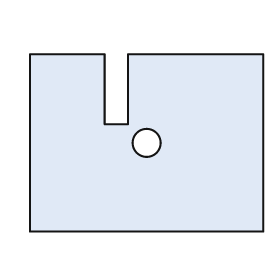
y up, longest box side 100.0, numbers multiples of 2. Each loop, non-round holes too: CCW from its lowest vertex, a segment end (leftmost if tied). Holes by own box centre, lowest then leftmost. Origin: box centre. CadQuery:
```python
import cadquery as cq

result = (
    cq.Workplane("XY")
    .moveTo(-50.0, -38.0)
    .lineTo(50.0, -38.0)
    .lineTo(50.0, 38.0)
    .lineTo(-8.0, 38.0)
    .lineTo(-8.0, 8.0)
    .lineTo(-18.0, 8.0)
    .lineTo(-18.0, 38.0)
    .lineTo(-50.0, 38.0)
    .close()
    .moveTo(0.0, 0.0)
    .circle(6.0)
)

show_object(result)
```